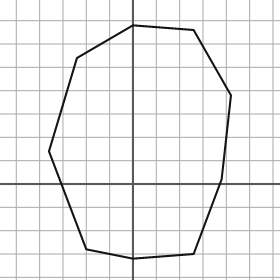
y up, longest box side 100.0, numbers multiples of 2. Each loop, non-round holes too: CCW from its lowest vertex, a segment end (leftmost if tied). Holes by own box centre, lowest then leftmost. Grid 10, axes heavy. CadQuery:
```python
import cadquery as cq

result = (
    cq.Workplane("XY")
    .moveTo(0.0, -32.0)
    .lineTo(26.0, -30.0)
    .lineTo(38.0, 2.0)
    .lineTo(42.0, 38.0)
    .lineTo(26.0, 66.0)
    .lineTo(0.0, 68.0)
    .lineTo(-24.0, 54.0)
    .lineTo(-36.0, 14.0)
    .lineTo(-20.0, -28.0)
    .close()
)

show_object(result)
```